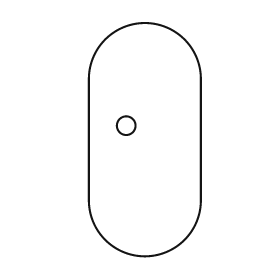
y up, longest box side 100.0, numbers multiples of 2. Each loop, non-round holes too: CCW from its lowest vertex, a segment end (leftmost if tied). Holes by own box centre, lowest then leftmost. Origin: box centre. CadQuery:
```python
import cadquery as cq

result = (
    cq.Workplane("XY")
    .moveTo(-24.0, -26.0)
    .threePointArc((0.0, -50.0), (24.0, -26.0))
    .lineTo(24.0, 26.0)
    .threePointArc((0.0, 50.0), (-24.0, 26.0))
    .close()
    .moveTo(-8.0, 6.0)
    .circle(4.0)
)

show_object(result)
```